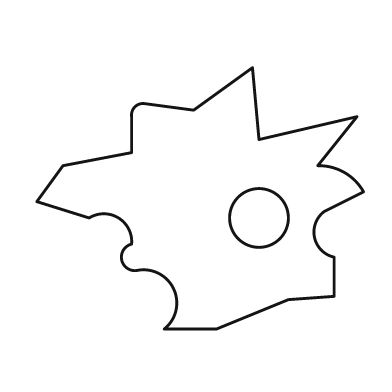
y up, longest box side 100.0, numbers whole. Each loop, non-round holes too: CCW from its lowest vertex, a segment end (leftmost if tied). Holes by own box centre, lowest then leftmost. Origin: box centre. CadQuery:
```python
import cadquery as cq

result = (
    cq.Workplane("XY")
    .moveTo(-11.0, -40.0)
    .lineTo(5.0, -40.0)
    .lineTo(27.0, -31.0)
    .lineTo(41.0, -30.0)
    .lineTo(41.0, -18.0)
    .threePointArc((35.0, -12.0), (38.0, -4.0))
    .lineTo(50.0, 2.0)
    .threePointArc((44.0, 8.0), (36.0, 10.0))
    .lineTo(48.0, 25.0)
    .lineTo(18.0, 18.0)
    .lineTo(16.0, 40.0)
    .lineTo(-2.0, 27.0)
    .lineTo(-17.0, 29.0)
    .threePointArc((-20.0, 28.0), (-21.0, 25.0))
    .lineTo(-21.0, 14.0)
    .lineTo(-42.0, 10.0)
    .lineTo(-50.0, -1.0)
    .lineTo(-34.0, -6.0)
    .threePointArc((-25.0, -6.0), (-21.0, -14.0))
    .threePointArc((-24.0, -19.0), (-19.0, -22.0))
    .threePointArc((-8.0, -28.0), (-11.0, -40.0))
    .close()
    .moveTo(18.0, -6.0)
    .circle(9.0)
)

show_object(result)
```